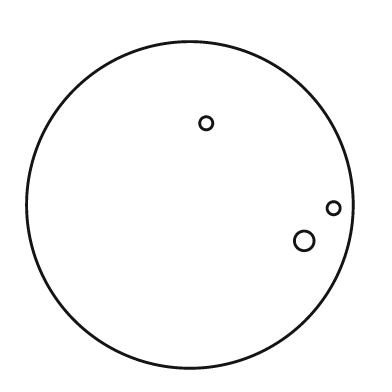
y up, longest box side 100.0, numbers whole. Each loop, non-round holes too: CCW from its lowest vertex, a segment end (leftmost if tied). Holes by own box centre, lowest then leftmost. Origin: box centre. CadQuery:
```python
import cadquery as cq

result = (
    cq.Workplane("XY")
    .moveTo(0.0, 0.0)
    .circle(50.0)
    .moveTo(35.0, -11.0)
    .circle(3.0)
    .moveTo(44.0, -1.0)
    .circle(2.0)
    .moveTo(5.0, 25.0)
    .circle(2.0)
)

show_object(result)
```